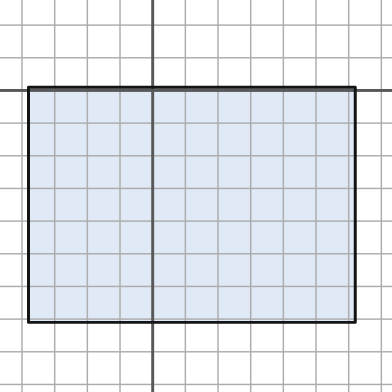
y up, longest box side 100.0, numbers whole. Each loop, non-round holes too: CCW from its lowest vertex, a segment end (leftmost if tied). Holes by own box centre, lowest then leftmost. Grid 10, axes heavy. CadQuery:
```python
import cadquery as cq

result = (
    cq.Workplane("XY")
    .moveTo(-38.0, -71.0)
    .lineTo(62.0, -71.0)
    .lineTo(62.0, 1.0)
    .lineTo(-38.0, 1.0)
    .close()
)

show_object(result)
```